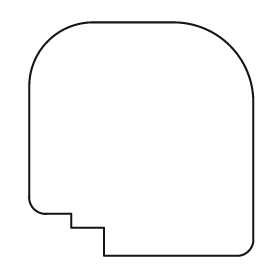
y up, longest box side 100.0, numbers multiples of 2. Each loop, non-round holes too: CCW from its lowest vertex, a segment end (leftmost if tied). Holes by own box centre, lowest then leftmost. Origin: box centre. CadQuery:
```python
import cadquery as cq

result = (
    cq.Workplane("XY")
    .moveTo(-16.0, -50.0)
    .lineTo(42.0, -50.0)
    .threePointArc((46.0, -48.0), (48.0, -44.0))
    .lineTo(48.0, 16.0)
    .threePointArc((38.0, 40.0), (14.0, 50.0))
    .lineTo(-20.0, 50.0)
    .threePointArc((-40.0, 42.0), (-48.0, 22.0))
    .lineTo(-48.0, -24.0)
    .threePointArc((-46.0, -30.0), (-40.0, -32.0))
    .lineTo(-30.0, -32.0)
    .lineTo(-30.0, -38.0)
    .lineTo(-16.0, -38.0)
    .close()
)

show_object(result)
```